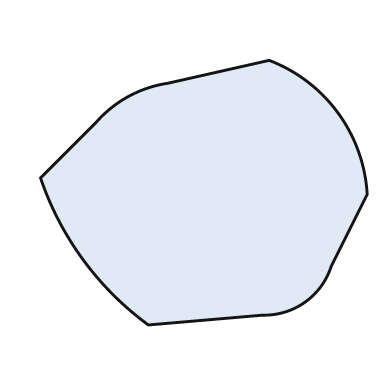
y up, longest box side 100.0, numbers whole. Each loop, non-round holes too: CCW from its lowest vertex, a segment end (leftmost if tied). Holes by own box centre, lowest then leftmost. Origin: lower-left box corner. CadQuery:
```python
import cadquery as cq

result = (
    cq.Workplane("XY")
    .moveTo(33.0, 0.0)
    .lineTo(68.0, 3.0)
    .threePointArc((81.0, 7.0), (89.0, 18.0))
    .lineTo(100.0, 40.0)
    .threePointArc((91.0, 65.0), (70.0, 81.0))
    .lineTo(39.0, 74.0)
    .threePointArc((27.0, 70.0), (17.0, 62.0))
    .lineTo(0.0, 45.0)
    .threePointArc((13.0, 20.0), (33.0, 0.0))
    .close()
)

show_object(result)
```